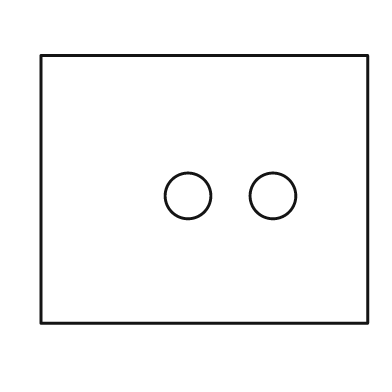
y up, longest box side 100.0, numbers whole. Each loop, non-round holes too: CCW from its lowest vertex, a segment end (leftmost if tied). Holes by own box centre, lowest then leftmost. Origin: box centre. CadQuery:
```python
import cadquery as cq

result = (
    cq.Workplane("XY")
    .moveTo(-50.0, -41.0)
    .lineTo(50.0, -41.0)
    .lineTo(50.0, 41.0)
    .lineTo(-50.0, 41.0)
    .close()
    .moveTo(-5.0, -2.0)
    .circle(7.0)
    .moveTo(21.0, -2.0)
    .circle(7.0)
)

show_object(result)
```